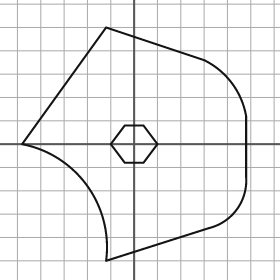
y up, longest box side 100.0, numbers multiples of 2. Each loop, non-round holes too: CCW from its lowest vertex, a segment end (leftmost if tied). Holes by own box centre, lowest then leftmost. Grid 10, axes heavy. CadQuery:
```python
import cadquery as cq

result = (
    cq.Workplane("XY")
    .moveTo(-12.0, -50.0)
    .lineTo(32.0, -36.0)
    .threePointArc((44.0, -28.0), (48.0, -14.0))
    .lineTo(48.0, 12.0)
    .threePointArc((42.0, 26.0), (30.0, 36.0))
    .lineTo(-12.0, 50.0)
    .lineTo(-48.0, 0.0)
    .threePointArc((-20.0, -18.0), (-12.0, -50.0))
    .close()
    .moveTo(-4.0, -8.0)
    .lineTo(4.0, -8.0)
    .lineTo(10.0, 0.0)
    .lineTo(4.0, 8.0)
    .lineTo(-4.0, 8.0)
    .lineTo(-10.0, 0.0)
    .close()
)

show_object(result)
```